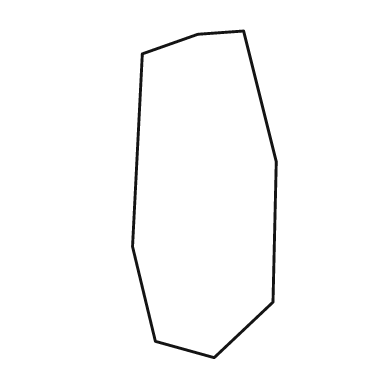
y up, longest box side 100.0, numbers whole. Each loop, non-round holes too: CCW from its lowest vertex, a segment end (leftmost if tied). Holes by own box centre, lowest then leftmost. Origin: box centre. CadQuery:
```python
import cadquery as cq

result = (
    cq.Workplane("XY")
    .moveTo(3.0, -50.0)
    .lineTo(21.0, -33.0)
    .lineTo(22.0, 10.0)
    .lineTo(12.0, 50.0)
    .lineTo(-2.0, 49.0)
    .lineTo(-19.0, 43.0)
    .lineTo(-22.0, -16.0)
    .lineTo(-15.0, -45.0)
    .close()
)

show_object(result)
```